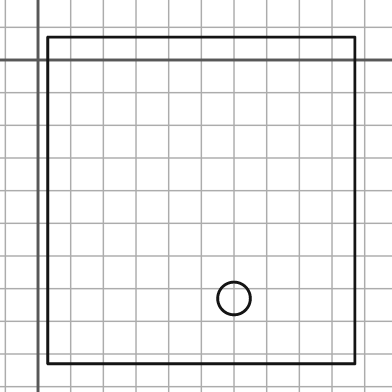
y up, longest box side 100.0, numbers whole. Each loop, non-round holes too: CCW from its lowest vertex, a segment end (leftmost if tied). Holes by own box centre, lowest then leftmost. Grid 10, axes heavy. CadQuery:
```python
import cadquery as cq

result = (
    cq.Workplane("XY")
    .moveTo(3.0, -93.0)
    .lineTo(97.0, -93.0)
    .lineTo(97.0, 7.0)
    .lineTo(3.0, 7.0)
    .close()
    .moveTo(60.0, -73.0)
    .circle(5.0)
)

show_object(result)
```